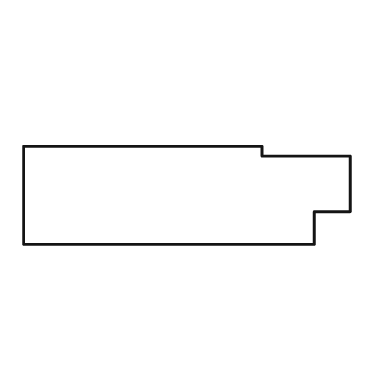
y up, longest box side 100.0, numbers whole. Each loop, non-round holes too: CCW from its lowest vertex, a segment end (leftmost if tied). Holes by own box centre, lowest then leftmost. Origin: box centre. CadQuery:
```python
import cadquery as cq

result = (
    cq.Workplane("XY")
    .moveTo(-50.0, -15.0)
    .lineTo(39.0, -15.0)
    .lineTo(39.0, -5.0)
    .lineTo(50.0, -5.0)
    .lineTo(50.0, 12.0)
    .lineTo(23.0, 12.0)
    .lineTo(23.0, 15.0)
    .lineTo(-50.0, 15.0)
    .close()
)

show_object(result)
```